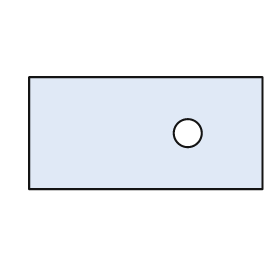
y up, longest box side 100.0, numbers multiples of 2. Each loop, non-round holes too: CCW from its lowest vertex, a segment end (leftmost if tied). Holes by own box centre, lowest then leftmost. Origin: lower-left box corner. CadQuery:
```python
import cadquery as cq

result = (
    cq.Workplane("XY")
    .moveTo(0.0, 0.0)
    .lineTo(100.0, 0.0)
    .lineTo(100.0, 48.0)
    .lineTo(0.0, 48.0)
    .close()
    .moveTo(68.0, 24.0)
    .circle(6.0)
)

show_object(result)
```